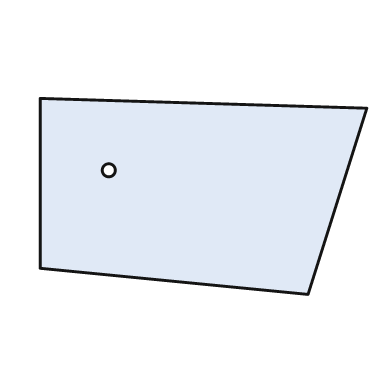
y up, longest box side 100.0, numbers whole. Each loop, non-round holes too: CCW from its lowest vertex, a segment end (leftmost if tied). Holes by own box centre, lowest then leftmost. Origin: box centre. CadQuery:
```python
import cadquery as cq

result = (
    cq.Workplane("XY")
    .moveTo(32.0, -30.0)
    .lineTo(50.0, 27.0)
    .lineTo(-50.0, 30.0)
    .lineTo(-50.0, -22.0)
    .close()
    .moveTo(-29.0, 8.0)
    .circle(2.0)
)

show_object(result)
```